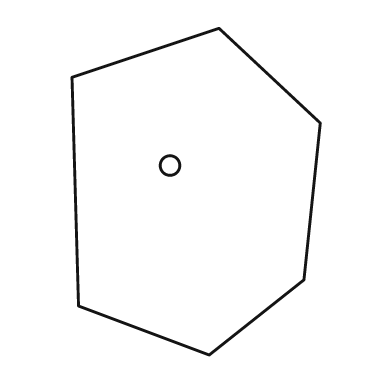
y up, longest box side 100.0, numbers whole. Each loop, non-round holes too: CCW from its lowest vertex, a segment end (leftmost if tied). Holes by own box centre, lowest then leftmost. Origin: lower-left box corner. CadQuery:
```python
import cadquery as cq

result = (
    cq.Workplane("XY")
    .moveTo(42.0, 0.0)
    .lineTo(71.0, 23.0)
    .lineTo(76.0, 71.0)
    .lineTo(45.0, 100.0)
    .lineTo(0.0, 85.0)
    .lineTo(2.0, 15.0)
    .close()
    .moveTo(30.0, 58.0)
    .circle(3.0)
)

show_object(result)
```